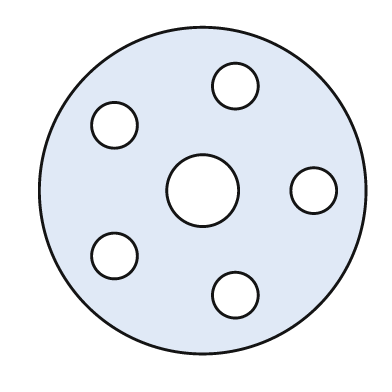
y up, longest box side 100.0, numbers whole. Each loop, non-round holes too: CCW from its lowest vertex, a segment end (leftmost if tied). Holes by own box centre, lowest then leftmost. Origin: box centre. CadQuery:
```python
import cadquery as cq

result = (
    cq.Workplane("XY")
    .moveTo(0.0, 0.0)
    .circle(50.0)
    .moveTo(10.0, -32.0)
    .circle(7.0)
    .moveTo(-27.0, -20.0)
    .circle(7.0)
    .moveTo(0.0, 0.0)
    .circle(11.0)
    .moveTo(34.0, 0.0)
    .circle(7.0)
    .moveTo(-27.0, 20.0)
    .circle(7.0)
    .moveTo(10.0, 32.0)
    .circle(7.0)
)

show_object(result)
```